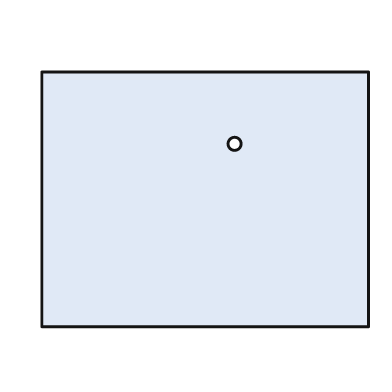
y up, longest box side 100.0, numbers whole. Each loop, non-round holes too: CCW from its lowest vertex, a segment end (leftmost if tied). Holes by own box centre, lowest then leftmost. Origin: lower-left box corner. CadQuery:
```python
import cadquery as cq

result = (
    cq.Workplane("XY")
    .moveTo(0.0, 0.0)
    .lineTo(100.0, 0.0)
    .lineTo(100.0, 78.0)
    .lineTo(0.0, 78.0)
    .close()
    .moveTo(59.0, 56.0)
    .circle(2.0)
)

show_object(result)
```